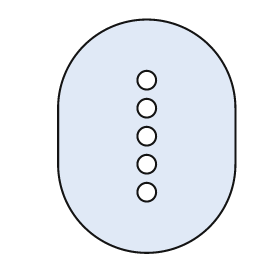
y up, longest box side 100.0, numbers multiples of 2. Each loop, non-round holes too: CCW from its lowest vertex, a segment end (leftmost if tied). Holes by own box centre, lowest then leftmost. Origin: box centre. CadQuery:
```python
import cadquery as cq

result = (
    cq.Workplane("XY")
    .moveTo(-38.0, -12.0)
    .threePointArc((0.0, -50.0), (38.0, -12.0))
    .lineTo(38.0, 12.0)
    .threePointArc((0.0, 50.0), (-38.0, 12.0))
    .close()
    .moveTo(0.0, -24.0)
    .circle(4.0)
    .moveTo(0.0, -12.0)
    .circle(4.0)
    .moveTo(0.0, 0.0)
    .circle(4.0)
    .moveTo(0.0, 12.0)
    .circle(4.0)
    .moveTo(0.0, 24.0)
    .circle(4.0)
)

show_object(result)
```